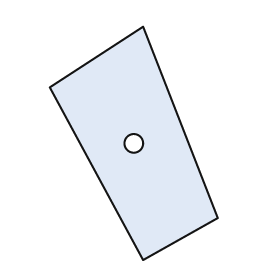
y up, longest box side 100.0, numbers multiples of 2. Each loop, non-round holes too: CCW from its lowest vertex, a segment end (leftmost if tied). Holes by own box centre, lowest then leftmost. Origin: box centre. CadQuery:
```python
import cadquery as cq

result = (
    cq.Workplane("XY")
    .moveTo(4.0, -50.0)
    .lineTo(36.0, -32.0)
    .lineTo(4.0, 50.0)
    .lineTo(-36.0, 24.0)
    .close()
    .moveTo(0.0, 0.0)
    .circle(4.0)
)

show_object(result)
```